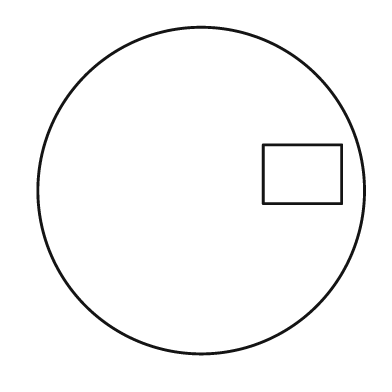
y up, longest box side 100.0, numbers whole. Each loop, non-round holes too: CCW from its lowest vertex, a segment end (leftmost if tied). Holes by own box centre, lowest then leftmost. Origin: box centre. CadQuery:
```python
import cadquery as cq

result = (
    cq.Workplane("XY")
    .moveTo(0.0, 0.0)
    .circle(50.0)
    .moveTo(19.0, -4.0)
    .lineTo(43.0, -4.0)
    .lineTo(43.0, 14.0)
    .lineTo(19.0, 14.0)
    .close()
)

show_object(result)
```